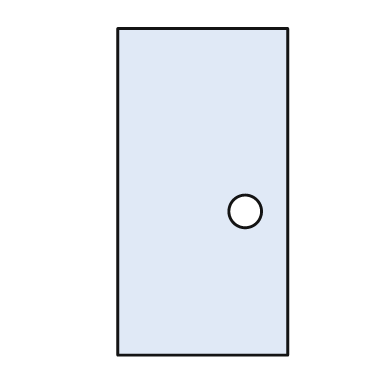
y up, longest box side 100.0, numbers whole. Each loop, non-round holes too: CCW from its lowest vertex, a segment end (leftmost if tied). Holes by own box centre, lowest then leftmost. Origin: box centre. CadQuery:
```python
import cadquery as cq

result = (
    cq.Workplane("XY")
    .moveTo(-26.0, -50.0)
    .lineTo(26.0, -50.0)
    .lineTo(26.0, 50.0)
    .lineTo(-26.0, 50.0)
    .close()
    .moveTo(13.0, -6.0)
    .circle(5.0)
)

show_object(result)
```